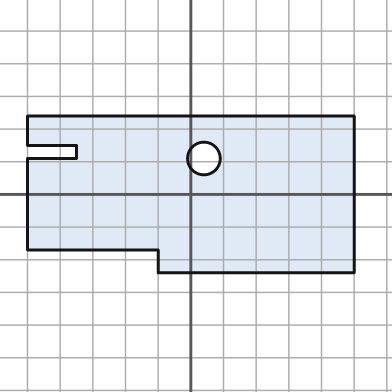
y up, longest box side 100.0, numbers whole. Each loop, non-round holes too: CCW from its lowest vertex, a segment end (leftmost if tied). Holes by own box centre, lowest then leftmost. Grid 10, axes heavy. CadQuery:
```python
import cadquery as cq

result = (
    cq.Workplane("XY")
    .moveTo(-10.0, -24.0)
    .lineTo(50.0, -24.0)
    .lineTo(50.0, 24.0)
    .lineTo(-50.0, 24.0)
    .lineTo(-50.0, 15.0)
    .lineTo(-35.0, 15.0)
    .lineTo(-35.0, 11.0)
    .lineTo(-50.0, 11.0)
    .lineTo(-50.0, -17.0)
    .lineTo(-10.0, -17.0)
    .close()
    .moveTo(4.0, 11.0)
    .circle(5.0)
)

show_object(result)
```